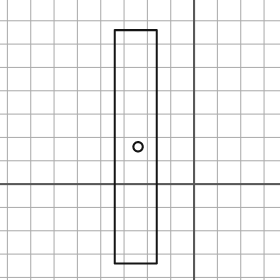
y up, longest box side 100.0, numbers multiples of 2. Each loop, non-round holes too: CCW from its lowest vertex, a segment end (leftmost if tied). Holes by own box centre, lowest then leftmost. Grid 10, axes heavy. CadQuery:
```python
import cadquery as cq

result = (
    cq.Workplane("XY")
    .moveTo(-34.0, -34.0)
    .lineTo(-16.0, -34.0)
    .lineTo(-16.0, 66.0)
    .lineTo(-34.0, 66.0)
    .close()
    .moveTo(-24.0, 16.0)
    .circle(2.0)
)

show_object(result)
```